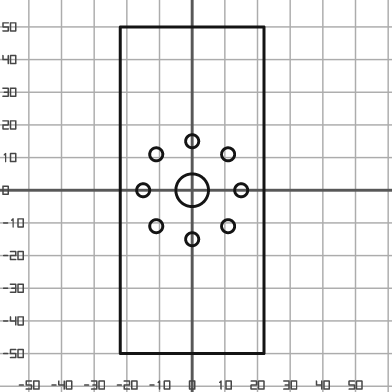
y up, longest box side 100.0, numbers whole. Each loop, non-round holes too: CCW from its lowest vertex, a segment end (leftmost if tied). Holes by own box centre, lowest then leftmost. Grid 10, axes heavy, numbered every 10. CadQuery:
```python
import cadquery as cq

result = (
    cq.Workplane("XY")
    .moveTo(-22.0, -50.0)
    .lineTo(22.0, -50.0)
    .lineTo(22.0, 50.0)
    .lineTo(-22.0, 50.0)
    .close()
    .moveTo(0.0, -15.0)
    .circle(2.0)
    .moveTo(-11.0, -11.0)
    .circle(2.0)
    .moveTo(11.0, -11.0)
    .circle(2.0)
    .moveTo(-15.0, 0.0)
    .circle(2.0)
    .moveTo(0.0, 0.0)
    .circle(5.0)
    .moveTo(15.0, 0.0)
    .circle(2.0)
    .moveTo(-11.0, 11.0)
    .circle(2.0)
    .moveTo(11.0, 11.0)
    .circle(2.0)
    .moveTo(0.0, 15.0)
    .circle(2.0)
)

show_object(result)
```